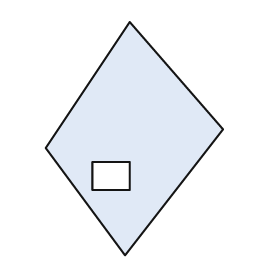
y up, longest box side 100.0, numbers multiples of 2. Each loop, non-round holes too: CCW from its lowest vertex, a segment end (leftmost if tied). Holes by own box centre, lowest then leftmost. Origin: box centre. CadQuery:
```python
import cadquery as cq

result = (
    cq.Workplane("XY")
    .moveTo(-4.0, -50.0)
    .lineTo(38.0, 4.0)
    .lineTo(-2.0, 50.0)
    .lineTo(-38.0, -4.0)
    .close()
    .moveTo(-18.0, -22.0)
    .lineTo(-2.0, -22.0)
    .lineTo(-2.0, -10.0)
    .lineTo(-18.0, -10.0)
    .close()
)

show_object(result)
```